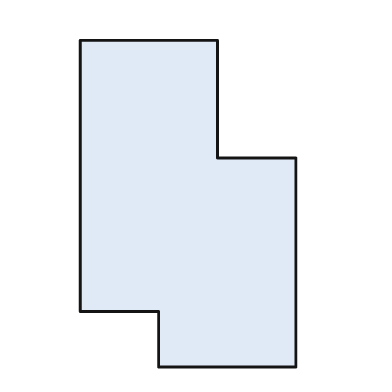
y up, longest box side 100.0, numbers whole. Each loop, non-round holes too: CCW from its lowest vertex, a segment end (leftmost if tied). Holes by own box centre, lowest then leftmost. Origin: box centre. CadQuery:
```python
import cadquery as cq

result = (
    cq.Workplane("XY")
    .moveTo(-9.0, -50.0)
    .lineTo(33.0, -50.0)
    .lineTo(33.0, 14.0)
    .lineTo(9.0, 14.0)
    .lineTo(9.0, 50.0)
    .lineTo(-33.0, 50.0)
    .lineTo(-33.0, -33.0)
    .lineTo(-9.0, -33.0)
    .close()
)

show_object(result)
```